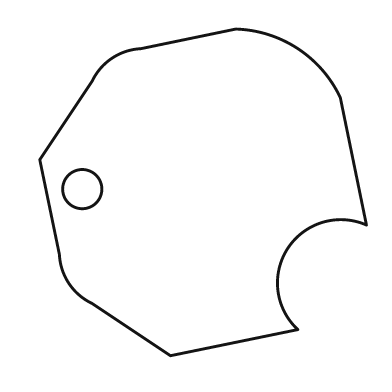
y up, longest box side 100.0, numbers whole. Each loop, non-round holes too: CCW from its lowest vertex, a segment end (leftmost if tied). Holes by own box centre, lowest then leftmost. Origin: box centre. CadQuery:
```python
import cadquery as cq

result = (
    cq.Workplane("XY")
    .moveTo(-10.0, -50.0)
    .lineTo(29.0, -42.0)
    .threePointArc((26.0, -17.0), (50.0, -10.0))
    .lineTo(42.0, 29.0)
    .threePointArc((29.0, 44.0), (10.0, 50.0))
    .lineTo(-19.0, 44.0)
    .threePointArc((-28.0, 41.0), (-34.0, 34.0))
    .lineTo(-50.0, 10.0)
    .lineTo(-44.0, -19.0)
    .threePointArc((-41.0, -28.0), (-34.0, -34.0))
    .close()
    .moveTo(-37.0, 1.0)
    .circle(6.0)
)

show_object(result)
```